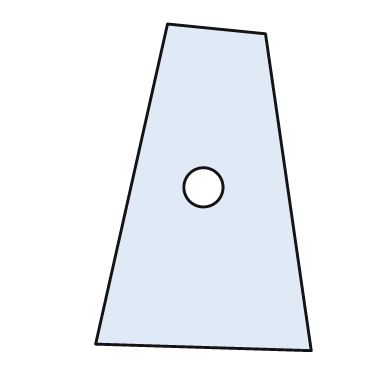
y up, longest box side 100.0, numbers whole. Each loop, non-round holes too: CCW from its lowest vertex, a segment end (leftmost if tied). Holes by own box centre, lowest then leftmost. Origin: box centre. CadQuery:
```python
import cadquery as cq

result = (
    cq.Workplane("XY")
    .moveTo(33.0, -50.0)
    .lineTo(19.0, 47.0)
    .lineTo(-11.0, 50.0)
    .lineTo(-33.0, -48.0)
    .close()
    .moveTo(0.0, 0.0)
    .circle(6.0)
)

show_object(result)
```